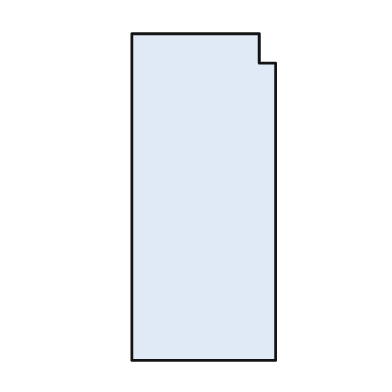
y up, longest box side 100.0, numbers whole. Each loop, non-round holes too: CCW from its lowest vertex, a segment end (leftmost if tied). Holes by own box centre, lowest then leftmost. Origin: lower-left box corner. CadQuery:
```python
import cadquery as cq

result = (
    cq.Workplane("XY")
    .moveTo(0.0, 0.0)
    .lineTo(44.0, 0.0)
    .lineTo(44.0, 91.0)
    .lineTo(39.0, 91.0)
    .lineTo(39.0, 100.0)
    .lineTo(0.0, 100.0)
    .close()
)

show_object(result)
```